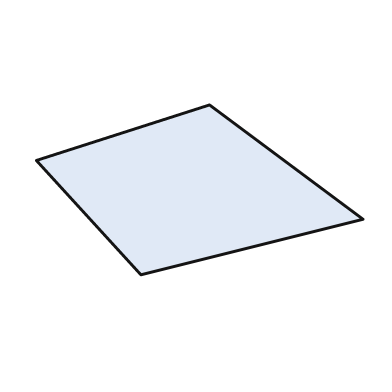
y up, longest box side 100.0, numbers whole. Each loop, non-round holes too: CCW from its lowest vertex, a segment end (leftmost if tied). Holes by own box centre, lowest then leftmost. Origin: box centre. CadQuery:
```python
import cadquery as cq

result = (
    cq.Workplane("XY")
    .moveTo(-18.0, -26.0)
    .lineTo(50.0, -9.0)
    .lineTo(3.0, 26.0)
    .lineTo(-50.0, 9.0)
    .close()
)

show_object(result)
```